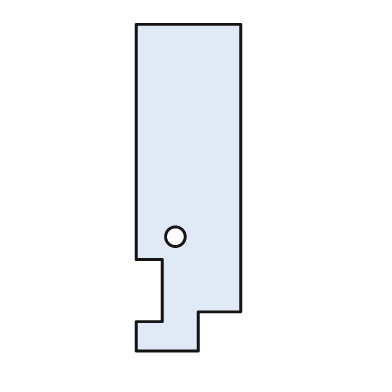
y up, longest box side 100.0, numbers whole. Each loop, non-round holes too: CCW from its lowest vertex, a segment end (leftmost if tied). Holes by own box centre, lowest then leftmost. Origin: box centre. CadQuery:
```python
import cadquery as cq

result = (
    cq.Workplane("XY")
    .moveTo(-16.0, -50.0)
    .lineTo(3.0, -50.0)
    .lineTo(3.0, -38.0)
    .lineTo(16.0, -38.0)
    .lineTo(16.0, 50.0)
    .lineTo(-16.0, 50.0)
    .lineTo(-16.0, -22.0)
    .lineTo(-8.0, -22.0)
    .lineTo(-8.0, -41.0)
    .lineTo(-16.0, -41.0)
    .close()
    .moveTo(-4.0, -15.0)
    .circle(3.0)
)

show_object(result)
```